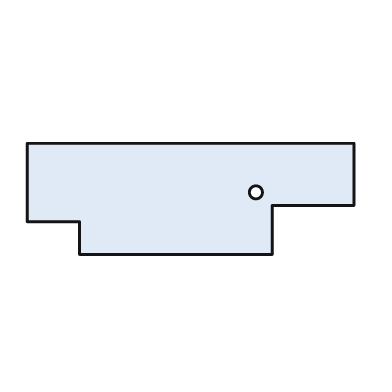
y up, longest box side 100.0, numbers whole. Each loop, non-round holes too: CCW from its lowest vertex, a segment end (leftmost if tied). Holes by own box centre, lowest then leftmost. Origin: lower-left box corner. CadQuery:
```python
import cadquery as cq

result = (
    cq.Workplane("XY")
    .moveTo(16.0, 0.0)
    .lineTo(75.0, 0.0)
    .lineTo(75.0, 15.0)
    .lineTo(100.0, 15.0)
    .lineTo(100.0, 34.0)
    .lineTo(0.0, 34.0)
    .lineTo(0.0, 10.0)
    .lineTo(16.0, 10.0)
    .close()
    .moveTo(70.0, 19.0)
    .circle(2.0)
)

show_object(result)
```